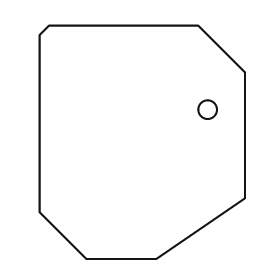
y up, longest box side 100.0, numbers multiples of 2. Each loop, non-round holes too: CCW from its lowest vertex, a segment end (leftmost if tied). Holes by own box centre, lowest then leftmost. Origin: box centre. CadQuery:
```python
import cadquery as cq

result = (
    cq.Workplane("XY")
    .moveTo(-24.0, -50.0)
    .lineTo(6.0, -50.0)
    .lineTo(44.0, -24.0)
    .lineTo(44.0, 30.0)
    .lineTo(24.0, 50.0)
    .lineTo(-40.0, 50.0)
    .lineTo(-44.0, 46.0)
    .lineTo(-44.0, -30.0)
    .close()
    .moveTo(28.0, 14.0)
    .circle(4.0)
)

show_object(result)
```